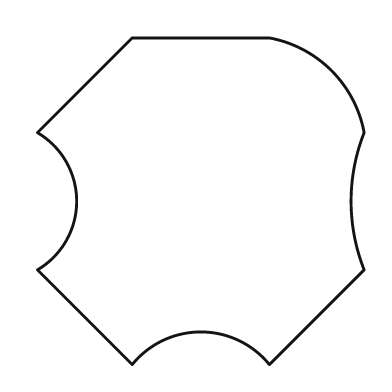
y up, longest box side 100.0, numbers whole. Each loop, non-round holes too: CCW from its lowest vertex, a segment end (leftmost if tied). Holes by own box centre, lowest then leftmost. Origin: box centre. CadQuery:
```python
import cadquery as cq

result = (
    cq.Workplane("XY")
    .moveTo(-21.0, -50.0)
    .threePointArc((0.0, -40.0), (21.0, -50.0))
    .lineTo(50.0, -21.0)
    .threePointArc((46.0, 0.0), (50.0, 21.0))
    .threePointArc((40.0, 40.0), (21.0, 50.0))
    .lineTo(-21.0, 50.0)
    .lineTo(-50.0, 21.0)
    .threePointArc((-38.0, 0.0), (-50.0, -21.0))
    .close()
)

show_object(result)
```